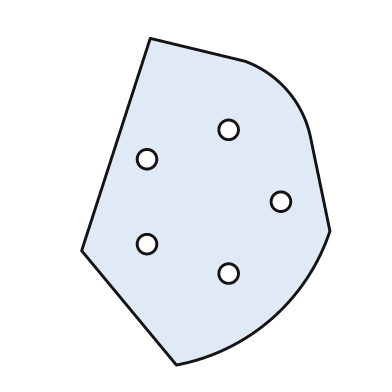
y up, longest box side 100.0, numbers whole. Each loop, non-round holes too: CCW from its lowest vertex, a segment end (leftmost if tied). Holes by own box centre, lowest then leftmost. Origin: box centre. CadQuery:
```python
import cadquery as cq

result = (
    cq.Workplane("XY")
    .moveTo(-9.0, -50.0)
    .threePointArc((20.0, -36.0), (38.0, -9.0))
    .lineTo(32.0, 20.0)
    .threePointArc((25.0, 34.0), (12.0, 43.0))
    .lineTo(-17.0, 50.0)
    .lineTo(-38.0, -15.0)
    .close()
    .moveTo(7.0, -22.0)
    .circle(3.0)
    .moveTo(-18.0, -13.0)
    .circle(3.0)
    .moveTo(23.0, 0.0)
    .circle(3.0)
    .moveTo(-18.0, 13.0)
    .circle(3.0)
    .moveTo(7.0, 22.0)
    .circle(3.0)
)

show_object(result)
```